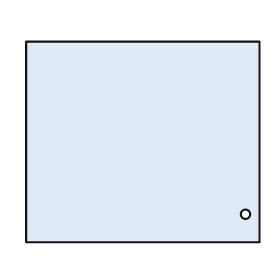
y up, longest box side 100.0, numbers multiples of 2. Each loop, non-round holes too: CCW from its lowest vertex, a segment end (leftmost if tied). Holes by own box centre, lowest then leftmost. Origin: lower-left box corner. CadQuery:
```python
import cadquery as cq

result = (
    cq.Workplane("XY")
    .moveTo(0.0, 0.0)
    .lineTo(100.0, 0.0)
    .lineTo(100.0, 86.0)
    .lineTo(0.0, 86.0)
    .close()
    .moveTo(94.0, 12.0)
    .circle(2.0)
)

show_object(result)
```